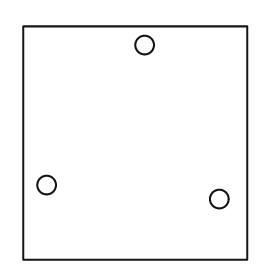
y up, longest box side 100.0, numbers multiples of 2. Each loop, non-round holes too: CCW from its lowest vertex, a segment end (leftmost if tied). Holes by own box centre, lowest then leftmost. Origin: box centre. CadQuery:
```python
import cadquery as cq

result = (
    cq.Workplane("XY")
    .moveTo(-48.0, -50.0)
    .lineTo(48.0, -50.0)
    .lineTo(48.0, 50.0)
    .lineTo(-48.0, 50.0)
    .close()
    .moveTo(36.0, -24.0)
    .circle(4.0)
    .moveTo(-38.0, -18.0)
    .circle(4.0)
    .moveTo(4.0, 42.0)
    .circle(4.0)
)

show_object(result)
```